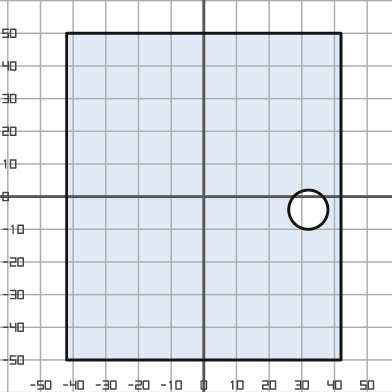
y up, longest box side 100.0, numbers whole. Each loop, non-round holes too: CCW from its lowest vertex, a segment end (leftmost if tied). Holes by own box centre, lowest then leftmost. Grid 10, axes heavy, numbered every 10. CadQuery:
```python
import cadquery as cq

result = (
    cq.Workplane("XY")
    .moveTo(-42.0, -50.0)
    .lineTo(42.0, -50.0)
    .lineTo(42.0, 50.0)
    .lineTo(-42.0, 50.0)
    .close()
    .moveTo(32.0, -4.0)
    .circle(6.0)
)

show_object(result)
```